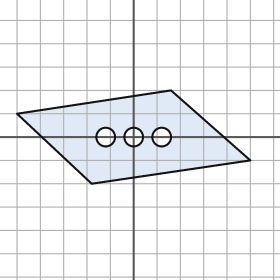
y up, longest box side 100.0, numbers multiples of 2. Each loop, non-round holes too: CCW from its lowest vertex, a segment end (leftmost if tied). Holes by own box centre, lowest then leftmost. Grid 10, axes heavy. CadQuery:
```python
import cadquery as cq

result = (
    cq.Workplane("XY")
    .moveTo(-18.0, -20.0)
    .lineTo(50.0, -10.0)
    .lineTo(16.0, 20.0)
    .lineTo(-50.0, 10.0)
    .close()
    .moveTo(-12.0, 0.0)
    .circle(4.0)
    .moveTo(0.0, 0.0)
    .circle(4.0)
    .moveTo(12.0, 0.0)
    .circle(4.0)
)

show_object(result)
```